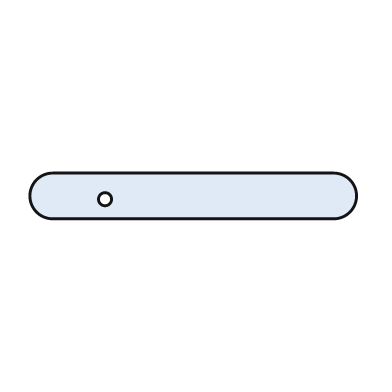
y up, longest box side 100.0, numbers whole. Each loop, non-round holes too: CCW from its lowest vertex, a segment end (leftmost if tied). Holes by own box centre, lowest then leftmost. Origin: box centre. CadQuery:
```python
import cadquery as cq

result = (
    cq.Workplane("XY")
    .moveTo(-43.0, -7.0)
    .lineTo(43.0, -7.0)
    .threePointArc((50.0, 0.0), (43.0, 7.0))
    .lineTo(-43.0, 7.0)
    .threePointArc((-50.0, 0.0), (-43.0, -7.0))
    .close()
    .moveTo(-27.0, -1.0)
    .circle(2.0)
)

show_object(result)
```